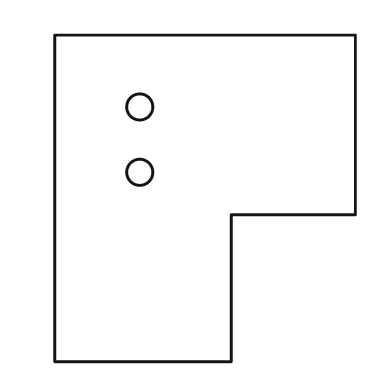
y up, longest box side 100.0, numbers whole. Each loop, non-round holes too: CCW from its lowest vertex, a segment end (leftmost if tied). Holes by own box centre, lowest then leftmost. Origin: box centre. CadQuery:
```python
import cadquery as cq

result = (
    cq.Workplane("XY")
    .moveTo(-46.0, -50.0)
    .lineTo(8.0, -50.0)
    .lineTo(8.0, -5.0)
    .lineTo(46.0, -5.0)
    .lineTo(46.0, 50.0)
    .lineTo(-46.0, 50.0)
    .close()
    .moveTo(-20.0, 8.0)
    .circle(4.0)
    .moveTo(-20.0, 28.0)
    .circle(4.0)
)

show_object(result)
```